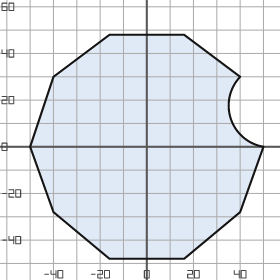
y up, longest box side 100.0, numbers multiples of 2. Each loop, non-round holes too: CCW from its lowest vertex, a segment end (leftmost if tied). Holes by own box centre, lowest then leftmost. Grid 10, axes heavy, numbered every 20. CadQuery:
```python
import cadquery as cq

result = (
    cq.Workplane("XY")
    .moveTo(-16.0, -48.0)
    .lineTo(16.0, -48.0)
    .lineTo(40.0, -28.0)
    .lineTo(50.0, 0.0)
    .threePointArc((36.0, 12.0), (40.0, 30.0))
    .lineTo(16.0, 48.0)
    .lineTo(-16.0, 48.0)
    .lineTo(-40.0, 30.0)
    .lineTo(-50.0, 0.0)
    .lineTo(-40.0, -28.0)
    .close()
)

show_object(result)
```